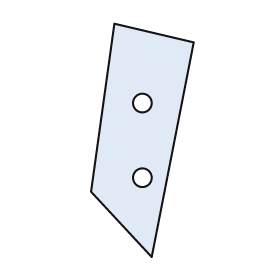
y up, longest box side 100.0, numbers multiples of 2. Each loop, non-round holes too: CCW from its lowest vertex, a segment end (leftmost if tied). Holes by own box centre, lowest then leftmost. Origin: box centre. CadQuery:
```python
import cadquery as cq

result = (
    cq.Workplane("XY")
    .moveTo(4.0, -50.0)
    .lineTo(22.0, 42.0)
    .lineTo(-12.0, 50.0)
    .lineTo(-22.0, -22.0)
    .close()
    .moveTo(0.0, -16.0)
    .circle(4.0)
    .moveTo(0.0, 16.0)
    .circle(4.0)
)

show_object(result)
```